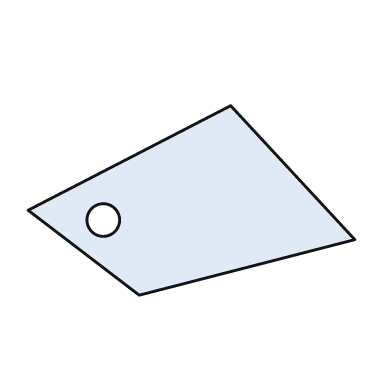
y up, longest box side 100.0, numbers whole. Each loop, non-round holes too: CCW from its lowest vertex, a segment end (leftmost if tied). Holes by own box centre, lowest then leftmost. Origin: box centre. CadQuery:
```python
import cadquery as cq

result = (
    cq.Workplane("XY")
    .moveTo(-16.0, -29.0)
    .lineTo(50.0, -12.0)
    .lineTo(12.0, 29.0)
    .lineTo(-50.0, -3.0)
    .close()
    .moveTo(-27.0, -6.0)
    .circle(5.0)
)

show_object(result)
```